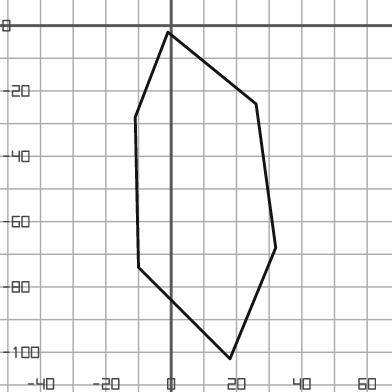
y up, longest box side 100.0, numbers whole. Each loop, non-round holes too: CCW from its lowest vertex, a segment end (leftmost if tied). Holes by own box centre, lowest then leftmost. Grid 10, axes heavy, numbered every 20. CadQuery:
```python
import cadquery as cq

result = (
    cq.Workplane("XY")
    .moveTo(18.0, -102.0)
    .lineTo(32.0, -68.0)
    .lineTo(26.0, -24.0)
    .lineTo(-1.0, -2.0)
    .lineTo(-11.0, -28.0)
    .lineTo(-10.0, -74.0)
    .close()
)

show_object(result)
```